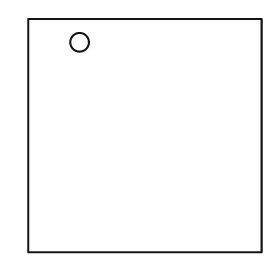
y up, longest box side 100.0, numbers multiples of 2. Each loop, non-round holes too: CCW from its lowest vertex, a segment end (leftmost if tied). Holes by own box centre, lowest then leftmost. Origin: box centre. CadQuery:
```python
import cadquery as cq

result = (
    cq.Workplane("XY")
    .moveTo(-50.0, -50.0)
    .lineTo(50.0, -50.0)
    .lineTo(50.0, 50.0)
    .lineTo(-50.0, 50.0)
    .close()
    .moveTo(-28.0, 40.0)
    .circle(4.0)
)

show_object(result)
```